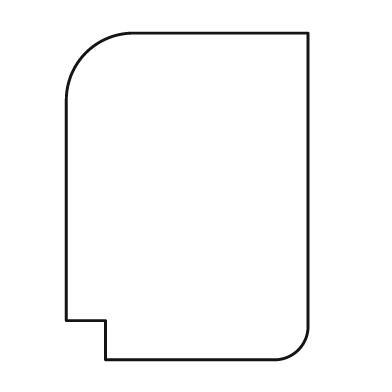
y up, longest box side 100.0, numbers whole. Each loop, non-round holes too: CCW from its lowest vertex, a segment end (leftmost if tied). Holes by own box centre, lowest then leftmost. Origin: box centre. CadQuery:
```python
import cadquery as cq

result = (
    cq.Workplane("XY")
    .moveTo(-25.0, -50.0)
    .lineTo(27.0, -50.0)
    .threePointArc((34.0, -47.0), (37.0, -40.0))
    .lineTo(37.0, 50.0)
    .lineTo(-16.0, 50.0)
    .threePointArc((-31.0, 44.0), (-37.0, 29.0))
    .lineTo(-37.0, -38.0)
    .lineTo(-25.0, -38.0)
    .close()
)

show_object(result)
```